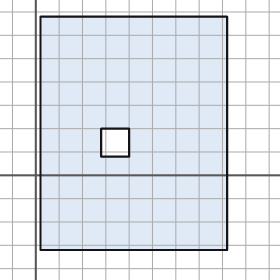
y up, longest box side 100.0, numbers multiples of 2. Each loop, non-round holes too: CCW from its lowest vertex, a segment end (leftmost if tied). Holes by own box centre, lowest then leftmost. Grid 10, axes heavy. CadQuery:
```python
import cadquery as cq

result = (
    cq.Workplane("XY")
    .moveTo(2.0, -32.0)
    .lineTo(82.0, -32.0)
    .lineTo(82.0, 68.0)
    .lineTo(2.0, 68.0)
    .close()
    .moveTo(28.0, 8.0)
    .lineTo(40.0, 8.0)
    .lineTo(40.0, 20.0)
    .lineTo(28.0, 20.0)
    .close()
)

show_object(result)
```